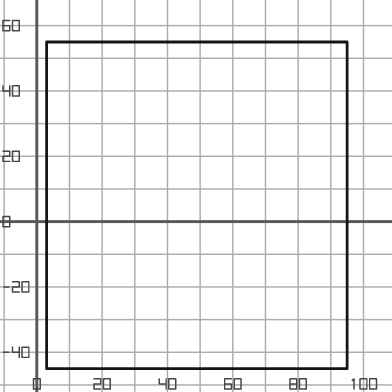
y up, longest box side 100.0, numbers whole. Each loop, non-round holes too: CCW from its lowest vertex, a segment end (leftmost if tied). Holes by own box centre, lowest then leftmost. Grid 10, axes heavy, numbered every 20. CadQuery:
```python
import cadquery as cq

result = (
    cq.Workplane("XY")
    .moveTo(3.0, -45.0)
    .lineTo(95.0, -45.0)
    .lineTo(95.0, 55.0)
    .lineTo(3.0, 55.0)
    .close()
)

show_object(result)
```